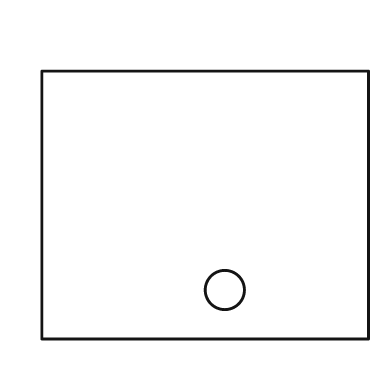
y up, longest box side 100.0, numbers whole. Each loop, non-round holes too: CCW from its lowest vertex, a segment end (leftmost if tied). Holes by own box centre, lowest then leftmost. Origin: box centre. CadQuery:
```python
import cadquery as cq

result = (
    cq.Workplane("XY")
    .moveTo(-50.0, -41.0)
    .lineTo(50.0, -41.0)
    .lineTo(50.0, 41.0)
    .lineTo(-50.0, 41.0)
    .close()
    .moveTo(6.0, -26.0)
    .circle(6.0)
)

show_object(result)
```